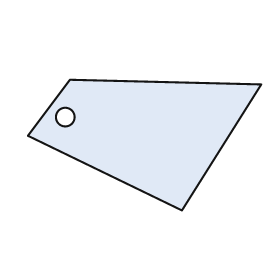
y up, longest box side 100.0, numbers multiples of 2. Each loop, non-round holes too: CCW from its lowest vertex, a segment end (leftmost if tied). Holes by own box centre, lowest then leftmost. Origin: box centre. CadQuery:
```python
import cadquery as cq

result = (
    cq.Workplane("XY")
    .moveTo(16.0, -28.0)
    .lineTo(50.0, 26.0)
    .lineTo(-32.0, 28.0)
    .lineTo(-50.0, 4.0)
    .close()
    .moveTo(-34.0, 12.0)
    .circle(4.0)
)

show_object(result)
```